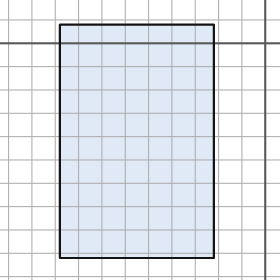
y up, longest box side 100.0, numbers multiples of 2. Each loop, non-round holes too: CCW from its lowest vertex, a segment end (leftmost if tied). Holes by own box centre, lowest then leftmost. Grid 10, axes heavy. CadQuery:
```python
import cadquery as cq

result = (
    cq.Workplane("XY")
    .moveTo(-88.0, -92.0)
    .lineTo(-22.0, -92.0)
    .lineTo(-22.0, 8.0)
    .lineTo(-88.0, 8.0)
    .close()
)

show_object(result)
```